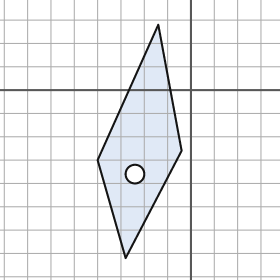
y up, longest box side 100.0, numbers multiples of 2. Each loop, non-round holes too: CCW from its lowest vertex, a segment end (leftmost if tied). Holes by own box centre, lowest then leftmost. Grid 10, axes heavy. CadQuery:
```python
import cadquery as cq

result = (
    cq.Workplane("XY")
    .moveTo(-28.0, -72.0)
    .lineTo(-4.0, -26.0)
    .lineTo(-14.0, 28.0)
    .lineTo(-40.0, -30.0)
    .close()
    .moveTo(-24.0, -36.0)
    .circle(4.0)
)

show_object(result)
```